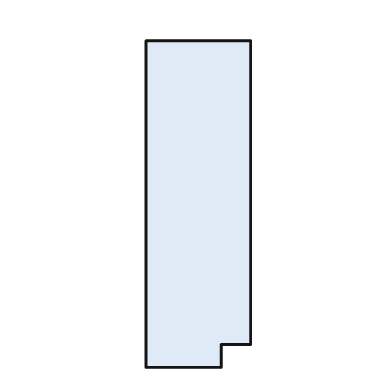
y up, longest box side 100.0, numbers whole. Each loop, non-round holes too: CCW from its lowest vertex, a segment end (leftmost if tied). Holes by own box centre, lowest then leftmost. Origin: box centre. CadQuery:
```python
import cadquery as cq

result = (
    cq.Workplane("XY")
    .moveTo(-16.0, -50.0)
    .lineTo(7.0, -50.0)
    .lineTo(7.0, -43.0)
    .lineTo(16.0, -43.0)
    .lineTo(16.0, 50.0)
    .lineTo(-16.0, 50.0)
    .close()
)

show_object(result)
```